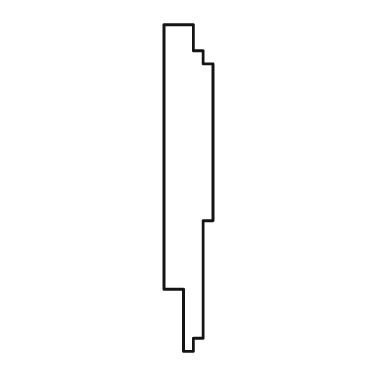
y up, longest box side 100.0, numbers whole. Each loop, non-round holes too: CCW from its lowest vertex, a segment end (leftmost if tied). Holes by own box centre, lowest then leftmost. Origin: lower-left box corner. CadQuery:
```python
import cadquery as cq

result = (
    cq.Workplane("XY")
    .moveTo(6.0, 0.0)
    .lineTo(9.0, 0.0)
    .lineTo(9.0, 4.0)
    .lineTo(12.0, 4.0)
    .lineTo(12.0, 40.0)
    .lineTo(15.0, 40.0)
    .lineTo(15.0, 88.0)
    .lineTo(12.0, 88.0)
    .lineTo(12.0, 92.0)
    .lineTo(9.0, 92.0)
    .lineTo(9.0, 100.0)
    .lineTo(0.0, 100.0)
    .lineTo(0.0, 19.0)
    .lineTo(6.0, 19.0)
    .close()
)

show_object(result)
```